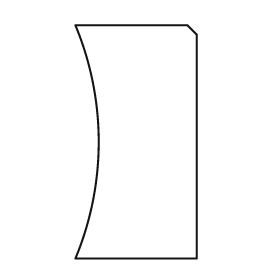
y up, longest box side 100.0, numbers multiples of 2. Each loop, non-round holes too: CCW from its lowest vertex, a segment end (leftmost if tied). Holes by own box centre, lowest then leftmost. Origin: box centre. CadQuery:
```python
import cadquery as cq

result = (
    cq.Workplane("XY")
    .moveTo(-26.0, -50.0)
    .lineTo(26.0, -50.0)
    .lineTo(26.0, 46.0)
    .lineTo(22.0, 50.0)
    .lineTo(-26.0, 50.0)
    .threePointArc((-16.0, 0.0), (-26.0, -50.0))
    .close()
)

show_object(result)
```